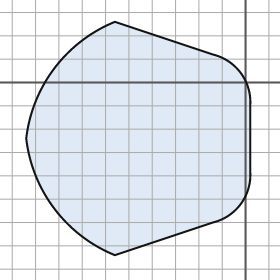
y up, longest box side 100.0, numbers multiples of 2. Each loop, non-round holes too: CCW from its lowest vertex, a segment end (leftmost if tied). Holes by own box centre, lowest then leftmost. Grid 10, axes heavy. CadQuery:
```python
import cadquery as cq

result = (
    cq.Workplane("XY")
    .moveTo(-56.0, -74.0)
    .lineTo(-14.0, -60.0)
    .threePointArc((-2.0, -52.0), (2.0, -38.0))
    .lineTo(2.0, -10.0)
    .threePointArc((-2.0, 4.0), (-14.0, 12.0))
    .lineTo(-56.0, 26.0)
    .threePointArc((-82.0, 6.0), (-94.0, -24.0))
    .threePointArc((-82.0, -54.0), (-56.0, -74.0))
    .close()
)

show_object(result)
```